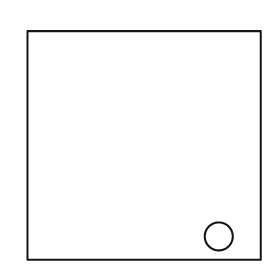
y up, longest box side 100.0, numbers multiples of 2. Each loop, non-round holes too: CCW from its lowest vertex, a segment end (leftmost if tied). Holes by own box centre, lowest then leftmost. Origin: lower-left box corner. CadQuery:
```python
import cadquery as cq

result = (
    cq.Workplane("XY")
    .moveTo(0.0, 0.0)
    .lineTo(100.0, 0.0)
    .lineTo(100.0, 98.0)
    .lineTo(0.0, 98.0)
    .close()
    .moveTo(82.0, 10.0)
    .circle(6.0)
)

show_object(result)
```